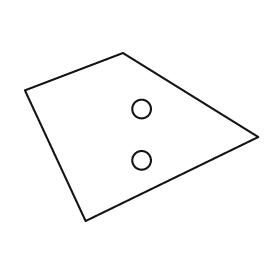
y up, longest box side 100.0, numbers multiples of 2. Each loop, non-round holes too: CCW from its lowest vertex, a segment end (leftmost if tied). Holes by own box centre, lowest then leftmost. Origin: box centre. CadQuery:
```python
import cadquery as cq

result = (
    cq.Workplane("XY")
    .moveTo(-24.0, -36.0)
    .lineTo(50.0, 0.0)
    .lineTo(-8.0, 36.0)
    .lineTo(-50.0, 20.0)
    .close()
    .moveTo(0.0, -10.0)
    .circle(4.0)
    .moveTo(0.0, 12.0)
    .circle(4.0)
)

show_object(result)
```